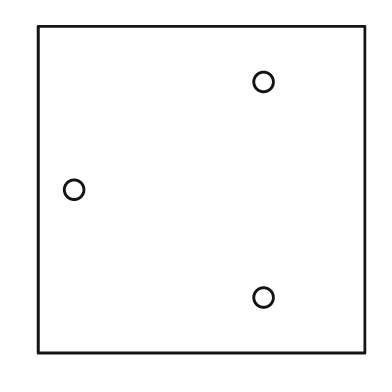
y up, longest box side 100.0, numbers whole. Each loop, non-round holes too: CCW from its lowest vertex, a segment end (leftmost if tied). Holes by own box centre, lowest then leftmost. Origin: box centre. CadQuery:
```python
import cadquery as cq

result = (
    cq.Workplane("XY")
    .moveTo(-50.0, -50.0)
    .lineTo(50.0, -50.0)
    .lineTo(50.0, 50.0)
    .lineTo(-50.0, 50.0)
    .close()
    .moveTo(19.0, -33.0)
    .circle(3.0)
    .moveTo(-39.0, 0.0)
    .circle(3.0)
    .moveTo(19.0, 33.0)
    .circle(3.0)
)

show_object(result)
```